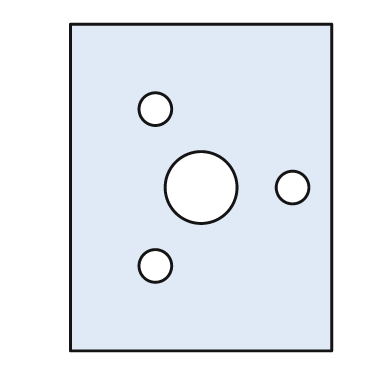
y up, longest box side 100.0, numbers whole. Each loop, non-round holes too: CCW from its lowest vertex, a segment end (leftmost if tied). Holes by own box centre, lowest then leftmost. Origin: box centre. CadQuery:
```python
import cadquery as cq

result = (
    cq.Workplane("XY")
    .moveTo(-40.0, -50.0)
    .lineTo(40.0, -50.0)
    .lineTo(40.0, 50.0)
    .lineTo(-40.0, 50.0)
    .close()
    .moveTo(-14.0, -24.0)
    .circle(5.0)
    .moveTo(0.0, 0.0)
    .circle(11.0)
    .moveTo(28.0, 0.0)
    .circle(5.0)
    .moveTo(-14.0, 24.0)
    .circle(5.0)
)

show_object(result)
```